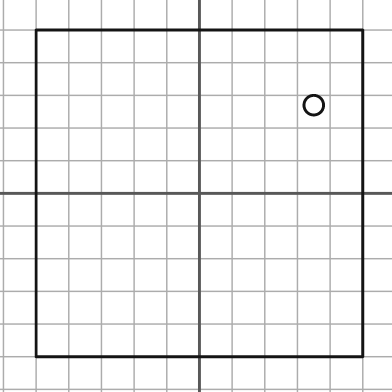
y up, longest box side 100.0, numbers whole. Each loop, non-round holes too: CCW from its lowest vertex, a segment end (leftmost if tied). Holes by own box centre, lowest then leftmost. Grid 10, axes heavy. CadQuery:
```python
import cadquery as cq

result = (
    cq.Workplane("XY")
    .moveTo(-50.0, -50.0)
    .lineTo(50.0, -50.0)
    .lineTo(50.0, 50.0)
    .lineTo(-50.0, 50.0)
    .close()
    .moveTo(35.0, 27.0)
    .circle(3.0)
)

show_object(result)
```